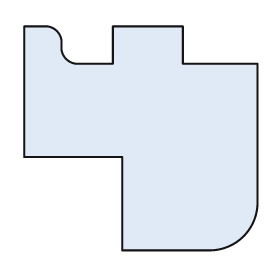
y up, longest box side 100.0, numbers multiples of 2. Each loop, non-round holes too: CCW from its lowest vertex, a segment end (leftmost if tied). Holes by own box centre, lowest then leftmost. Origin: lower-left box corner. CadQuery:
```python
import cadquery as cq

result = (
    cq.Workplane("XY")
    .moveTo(42.0, 0.0)
    .lineTo(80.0, 0.0)
    .threePointArc((94.0, 6.0), (100.0, 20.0))
    .lineTo(100.0, 80.0)
    .lineTo(68.0, 80.0)
    .lineTo(68.0, 96.0)
    .lineTo(38.0, 96.0)
    .lineTo(38.0, 80.0)
    .lineTo(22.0, 80.0)
    .threePointArc((18.0, 82.0), (16.0, 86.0))
    .lineTo(16.0, 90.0)
    .threePointArc((14.0, 94.0), (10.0, 96.0))
    .lineTo(0.0, 96.0)
    .lineTo(0.0, 40.0)
    .lineTo(42.0, 40.0)
    .close()
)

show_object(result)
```